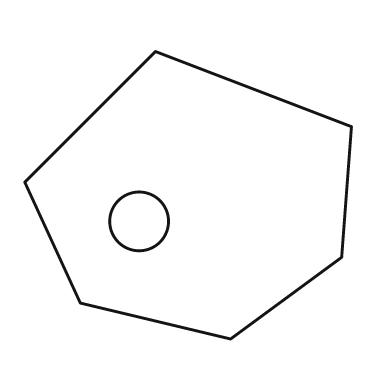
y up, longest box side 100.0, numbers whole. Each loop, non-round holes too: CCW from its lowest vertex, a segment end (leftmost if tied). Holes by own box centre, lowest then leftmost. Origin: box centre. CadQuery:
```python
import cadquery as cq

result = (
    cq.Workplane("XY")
    .moveTo(13.0, -44.0)
    .lineTo(47.0, -19.0)
    .lineTo(50.0, 21.0)
    .lineTo(-10.0, 44.0)
    .lineTo(-50.0, 4.0)
    .lineTo(-33.0, -33.0)
    .close()
    .moveTo(-15.0, -8.0)
    .circle(9.0)
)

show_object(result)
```